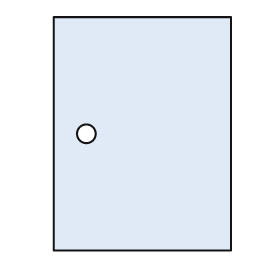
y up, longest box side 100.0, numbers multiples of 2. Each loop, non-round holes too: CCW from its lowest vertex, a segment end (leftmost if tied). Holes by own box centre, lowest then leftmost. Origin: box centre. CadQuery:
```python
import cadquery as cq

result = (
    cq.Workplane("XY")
    .moveTo(-38.0, -50.0)
    .lineTo(38.0, -50.0)
    .lineTo(38.0, 50.0)
    .lineTo(-38.0, 50.0)
    .close()
    .moveTo(-24.0, 0.0)
    .circle(4.0)
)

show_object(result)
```